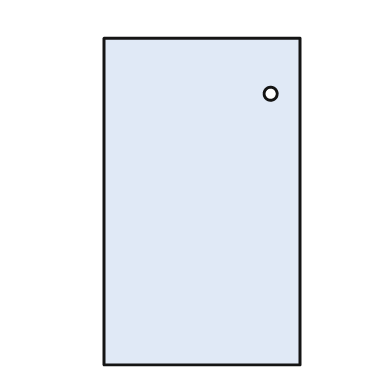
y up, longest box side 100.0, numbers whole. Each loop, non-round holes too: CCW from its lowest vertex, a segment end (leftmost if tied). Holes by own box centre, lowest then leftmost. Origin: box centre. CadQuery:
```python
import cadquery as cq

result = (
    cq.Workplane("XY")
    .moveTo(-30.0, -50.0)
    .lineTo(30.0, -50.0)
    .lineTo(30.0, 50.0)
    .lineTo(-30.0, 50.0)
    .close()
    .moveTo(21.0, 33.0)
    .circle(2.0)
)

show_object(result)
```